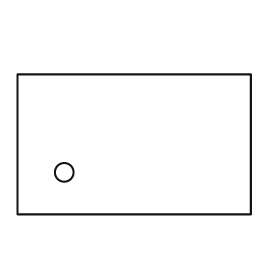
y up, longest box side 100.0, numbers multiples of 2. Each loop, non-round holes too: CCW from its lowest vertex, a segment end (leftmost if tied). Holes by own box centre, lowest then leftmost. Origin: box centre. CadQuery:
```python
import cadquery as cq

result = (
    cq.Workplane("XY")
    .moveTo(-50.0, -30.0)
    .lineTo(50.0, -30.0)
    .lineTo(50.0, 30.0)
    .lineTo(-50.0, 30.0)
    .close()
    .moveTo(-30.0, -12.0)
    .circle(4.0)
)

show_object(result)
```